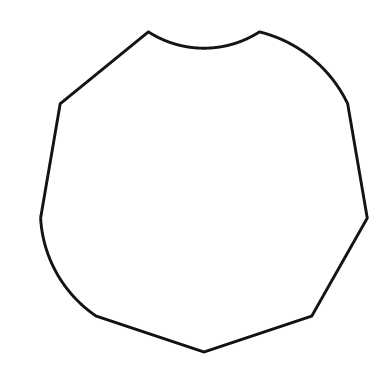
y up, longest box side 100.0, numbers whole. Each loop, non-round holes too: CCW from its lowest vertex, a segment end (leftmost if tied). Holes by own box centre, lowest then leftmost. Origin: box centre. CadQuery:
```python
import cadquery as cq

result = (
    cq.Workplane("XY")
    .moveTo(0.0, -49.0)
    .lineTo(33.0, -38.0)
    .lineTo(50.0, -8.0)
    .lineTo(44.0, 27.0)
    .threePointArc((33.0, 41.0), (17.0, 49.0))
    .threePointArc((0.0, 44.0), (-17.0, 49.0))
    .lineTo(-44.0, 27.0)
    .lineTo(-50.0, -8.0)
    .threePointArc((-45.0, -25.0), (-33.0, -38.0))
    .close()
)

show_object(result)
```